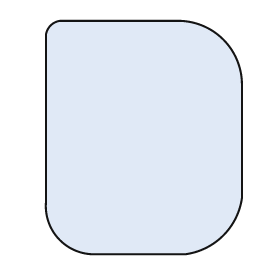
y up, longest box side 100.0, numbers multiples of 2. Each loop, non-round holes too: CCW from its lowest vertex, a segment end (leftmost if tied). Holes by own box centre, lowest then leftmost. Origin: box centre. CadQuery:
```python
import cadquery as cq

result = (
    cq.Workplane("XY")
    .moveTo(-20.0, -50.0)
    .lineTo(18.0, -50.0)
    .threePointArc((34.0, -42.0), (42.0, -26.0))
    .lineTo(42.0, 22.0)
    .threePointArc((34.0, 42.0), (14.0, 50.0))
    .lineTo(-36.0, 50.0)
    .threePointArc((-40.0, 48.0), (-42.0, 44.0))
    .lineTo(-42.0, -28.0)
    .threePointArc((-36.0, -44.0), (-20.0, -50.0))
    .close()
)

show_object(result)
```